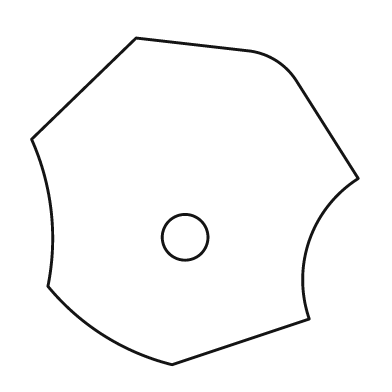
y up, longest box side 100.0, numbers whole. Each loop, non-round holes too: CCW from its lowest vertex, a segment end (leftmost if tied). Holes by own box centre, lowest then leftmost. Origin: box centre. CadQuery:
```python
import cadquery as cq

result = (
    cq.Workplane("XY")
    .moveTo(-7.0, -50.0)
    .lineTo(35.0, -36.0)
    .threePointArc((35.0, -12.0), (50.0, 7.0))
    .lineTo(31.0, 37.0)
    .threePointArc((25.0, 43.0), (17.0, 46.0))
    .lineTo(-18.0, 50.0)
    .lineTo(-50.0, 19.0)
    .threePointArc((-44.0, -3.0), (-45.0, -26.0))
    .threePointArc((-28.0, -41.0), (-7.0, -50.0))
    .close()
    .moveTo(-3.0, -11.0)
    .circle(7.0)
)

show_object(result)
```